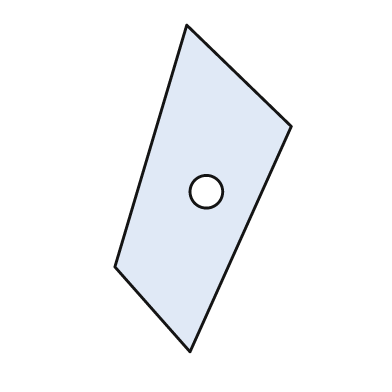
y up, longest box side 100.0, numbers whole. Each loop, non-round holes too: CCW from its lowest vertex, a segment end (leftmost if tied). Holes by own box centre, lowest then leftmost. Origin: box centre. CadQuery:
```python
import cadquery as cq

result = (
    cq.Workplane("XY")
    .moveTo(-4.0, -50.0)
    .lineTo(27.0, 19.0)
    .lineTo(-5.0, 50.0)
    .lineTo(-27.0, -24.0)
    .close()
    .moveTo(1.0, -1.0)
    .circle(5.0)
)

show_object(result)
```